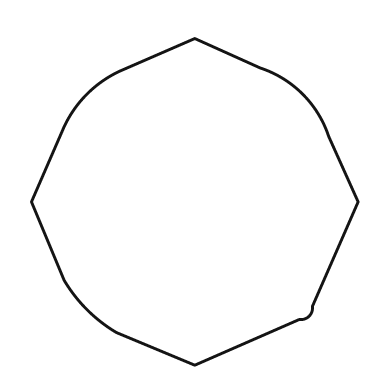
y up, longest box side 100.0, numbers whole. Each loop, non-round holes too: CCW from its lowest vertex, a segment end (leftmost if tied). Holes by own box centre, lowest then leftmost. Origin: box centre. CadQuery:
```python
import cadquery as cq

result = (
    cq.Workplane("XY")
    .moveTo(0.0, -50.0)
    .lineTo(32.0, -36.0)
    .threePointArc((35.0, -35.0), (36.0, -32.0))
    .lineTo(50.0, 0.0)
    .lineTo(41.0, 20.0)
    .threePointArc((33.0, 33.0), (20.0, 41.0))
    .lineTo(0.0, 50.0)
    .lineTo(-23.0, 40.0)
    .threePointArc((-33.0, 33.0), (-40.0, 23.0))
    .lineTo(-50.0, 0.0)
    .lineTo(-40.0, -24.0)
    .threePointArc((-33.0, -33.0), (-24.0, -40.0))
    .close()
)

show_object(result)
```